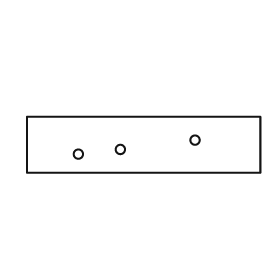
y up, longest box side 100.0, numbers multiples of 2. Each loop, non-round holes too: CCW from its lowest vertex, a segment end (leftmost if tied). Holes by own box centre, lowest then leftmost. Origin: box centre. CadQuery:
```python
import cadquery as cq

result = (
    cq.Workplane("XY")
    .moveTo(-50.0, -12.0)
    .lineTo(50.0, -12.0)
    .lineTo(50.0, 12.0)
    .lineTo(-50.0, 12.0)
    .close()
    .moveTo(-28.0, -4.0)
    .circle(2.0)
    .moveTo(-10.0, -2.0)
    .circle(2.0)
    .moveTo(22.0, 2.0)
    .circle(2.0)
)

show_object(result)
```